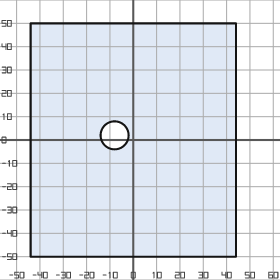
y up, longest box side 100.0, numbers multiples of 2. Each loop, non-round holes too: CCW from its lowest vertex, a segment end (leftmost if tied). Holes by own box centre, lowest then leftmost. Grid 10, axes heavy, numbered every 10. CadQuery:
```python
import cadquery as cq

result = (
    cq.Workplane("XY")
    .moveTo(-44.0, -50.0)
    .lineTo(44.0, -50.0)
    .lineTo(44.0, 50.0)
    .lineTo(-44.0, 50.0)
    .close()
    .moveTo(-8.0, 2.0)
    .circle(6.0)
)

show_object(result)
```